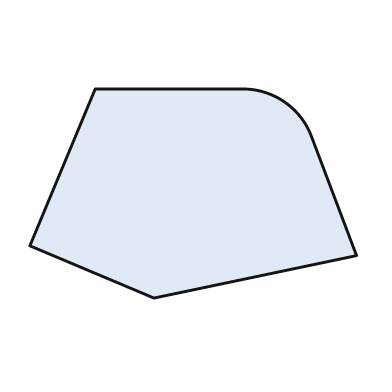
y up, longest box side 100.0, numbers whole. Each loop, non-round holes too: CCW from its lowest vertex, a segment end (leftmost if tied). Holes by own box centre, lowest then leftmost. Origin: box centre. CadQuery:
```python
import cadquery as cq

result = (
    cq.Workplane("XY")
    .moveTo(-12.0, -32.0)
    .lineTo(50.0, -19.0)
    .lineTo(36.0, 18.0)
    .threePointArc((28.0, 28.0), (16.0, 32.0))
    .lineTo(-30.0, 32.0)
    .lineTo(-50.0, -16.0)
    .close()
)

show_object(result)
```